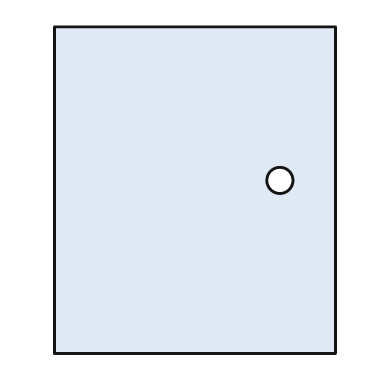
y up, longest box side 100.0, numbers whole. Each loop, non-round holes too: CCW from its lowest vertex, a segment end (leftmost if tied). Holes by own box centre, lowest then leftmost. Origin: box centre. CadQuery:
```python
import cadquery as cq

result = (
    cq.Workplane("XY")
    .moveTo(-43.0, -50.0)
    .lineTo(43.0, -50.0)
    .lineTo(43.0, 50.0)
    .lineTo(-43.0, 50.0)
    .close()
    .moveTo(26.0, 3.0)
    .circle(4.0)
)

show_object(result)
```